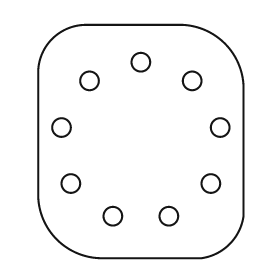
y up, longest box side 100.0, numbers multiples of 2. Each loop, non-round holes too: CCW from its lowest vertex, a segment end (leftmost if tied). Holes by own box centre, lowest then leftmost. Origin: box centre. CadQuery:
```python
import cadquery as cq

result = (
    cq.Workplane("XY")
    .moveTo(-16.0, -50.0)
    .lineTo(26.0, -50.0)
    .threePointArc((38.0, -44.0), (44.0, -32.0))
    .lineTo(44.0, 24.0)
    .threePointArc((36.0, 42.0), (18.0, 50.0))
    .lineTo(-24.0, 50.0)
    .threePointArc((-38.0, 44.0), (-44.0, 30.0))
    .lineTo(-44.0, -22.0)
    .threePointArc((-36.0, -42.0), (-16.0, -50.0))
    .close()
    .moveTo(-12.0, -32.0)
    .circle(4.0)
    .moveTo(12.0, -32.0)
    .circle(4.0)
    .moveTo(-30.0, -18.0)
    .circle(4.0)
    .moveTo(30.0, -18.0)
    .circle(4.0)
    .moveTo(-34.0, 6.0)
    .circle(4.0)
    .moveTo(34.0, 6.0)
    .circle(4.0)
    .moveTo(-22.0, 26.0)
    .circle(4.0)
    .moveTo(22.0, 26.0)
    .circle(4.0)
    .moveTo(0.0, 34.0)
    .circle(4.0)
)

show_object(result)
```